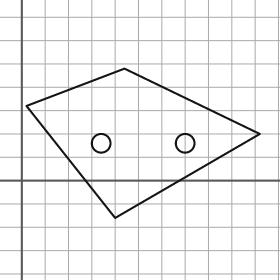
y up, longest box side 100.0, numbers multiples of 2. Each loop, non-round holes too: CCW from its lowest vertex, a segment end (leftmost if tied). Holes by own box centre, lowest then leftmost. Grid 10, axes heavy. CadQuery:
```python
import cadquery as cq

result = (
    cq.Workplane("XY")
    .moveTo(40.0, -16.0)
    .lineTo(102.0, 20.0)
    .lineTo(44.0, 48.0)
    .lineTo(2.0, 32.0)
    .close()
    .moveTo(34.0, 16.0)
    .circle(4.0)
    .moveTo(70.0, 16.0)
    .circle(4.0)
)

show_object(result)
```